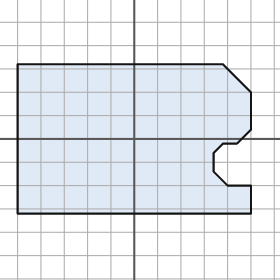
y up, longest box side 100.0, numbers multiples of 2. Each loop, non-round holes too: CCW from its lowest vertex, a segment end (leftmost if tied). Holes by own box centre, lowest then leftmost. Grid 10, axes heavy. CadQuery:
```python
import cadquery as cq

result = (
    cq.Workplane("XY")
    .moveTo(-50.0, -32.0)
    .lineTo(50.0, -32.0)
    .lineTo(50.0, -20.0)
    .lineTo(40.0, -20.0)
    .lineTo(34.0, -14.0)
    .lineTo(34.0, -6.0)
    .lineTo(38.0, -2.0)
    .lineTo(44.0, -2.0)
    .lineTo(50.0, 4.0)
    .lineTo(50.0, 20.0)
    .lineTo(38.0, 32.0)
    .lineTo(-50.0, 32.0)
    .close()
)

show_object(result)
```